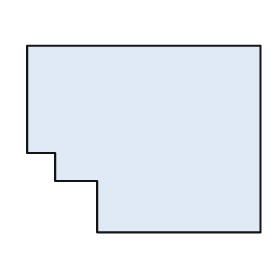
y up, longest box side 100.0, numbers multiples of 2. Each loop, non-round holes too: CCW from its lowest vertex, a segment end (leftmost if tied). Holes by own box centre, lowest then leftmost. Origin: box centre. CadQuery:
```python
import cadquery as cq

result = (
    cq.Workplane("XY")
    .moveTo(-20.0, -40.0)
    .lineTo(50.0, -40.0)
    .lineTo(50.0, 40.0)
    .lineTo(-50.0, 40.0)
    .lineTo(-50.0, -6.0)
    .lineTo(-38.0, -6.0)
    .lineTo(-38.0, -18.0)
    .lineTo(-20.0, -18.0)
    .close()
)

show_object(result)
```